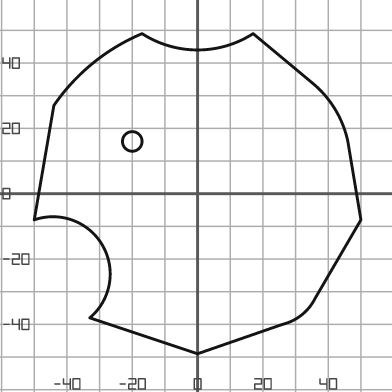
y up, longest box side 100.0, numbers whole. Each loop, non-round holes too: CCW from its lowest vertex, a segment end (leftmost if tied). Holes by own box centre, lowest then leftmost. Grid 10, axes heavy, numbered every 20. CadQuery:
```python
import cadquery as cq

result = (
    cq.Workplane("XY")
    .moveTo(0.0, -49.0)
    .lineTo(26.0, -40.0)
    .threePointArc((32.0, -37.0), (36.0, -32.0))
    .lineTo(50.0, -8.0)
    .lineTo(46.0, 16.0)
    .threePointArc((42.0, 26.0), (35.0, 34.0))
    .lineTo(17.0, 49.0)
    .threePointArc((0.0, 44.0), (-17.0, 49.0))
    .threePointArc((-32.0, 40.0), (-44.0, 27.0))
    .lineTo(-50.0, -8.0)
    .threePointArc((-29.0, -16.0), (-33.0, -38.0))
    .close()
    .moveTo(-20.0, 16.0)
    .circle(3.0)
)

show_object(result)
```